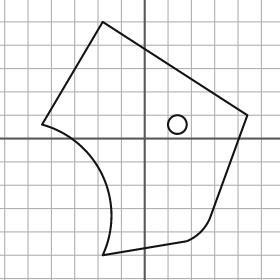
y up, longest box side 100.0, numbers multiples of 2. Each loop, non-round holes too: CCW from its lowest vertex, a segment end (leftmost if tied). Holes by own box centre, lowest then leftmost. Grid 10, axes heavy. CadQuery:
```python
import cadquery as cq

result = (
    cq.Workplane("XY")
    .moveTo(-18.0, -50.0)
    .lineTo(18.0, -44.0)
    .threePointArc((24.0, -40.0), (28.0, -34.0))
    .lineTo(44.0, 10.0)
    .lineTo(-18.0, 50.0)
    .lineTo(-44.0, 6.0)
    .threePointArc((-18.0, -16.0), (-18.0, -50.0))
    .close()
    .moveTo(14.0, 6.0)
    .circle(4.0)
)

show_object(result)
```